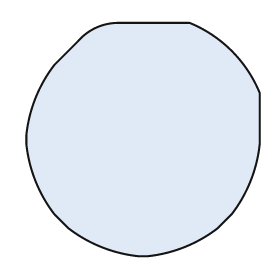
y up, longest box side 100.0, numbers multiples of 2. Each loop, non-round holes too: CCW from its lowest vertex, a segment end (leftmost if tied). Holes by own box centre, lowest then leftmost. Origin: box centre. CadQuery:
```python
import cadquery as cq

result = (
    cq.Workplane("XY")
    .moveTo(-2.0, -50.0)
    .lineTo(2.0, -50.0)
    .threePointArc((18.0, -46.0), (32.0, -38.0))
    .lineTo(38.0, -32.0)
    .threePointArc((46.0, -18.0), (50.0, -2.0))
    .lineTo(50.0, 20.0)
    .threePointArc((38.0, 38.0), (20.0, 50.0))
    .lineTo(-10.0, 50.0)
    .threePointArc((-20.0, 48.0), (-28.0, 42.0))
    .lineTo(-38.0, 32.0)
    .threePointArc((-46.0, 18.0), (-50.0, 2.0))
    .lineTo(-50.0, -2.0)
    .threePointArc((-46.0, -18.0), (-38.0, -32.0))
    .lineTo(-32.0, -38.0)
    .threePointArc((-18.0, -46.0), (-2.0, -50.0))
    .close()
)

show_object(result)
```